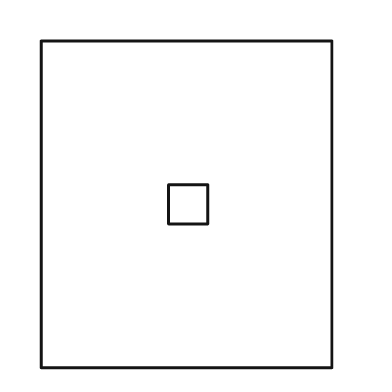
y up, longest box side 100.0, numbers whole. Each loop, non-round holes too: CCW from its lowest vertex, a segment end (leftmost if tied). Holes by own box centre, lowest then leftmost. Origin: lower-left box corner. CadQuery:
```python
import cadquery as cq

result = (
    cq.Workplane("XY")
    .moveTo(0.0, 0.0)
    .lineTo(89.0, 0.0)
    .lineTo(89.0, 100.0)
    .lineTo(0.0, 100.0)
    .close()
    .moveTo(39.0, 44.0)
    .lineTo(51.0, 44.0)
    .lineTo(51.0, 56.0)
    .lineTo(39.0, 56.0)
    .close()
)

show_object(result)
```